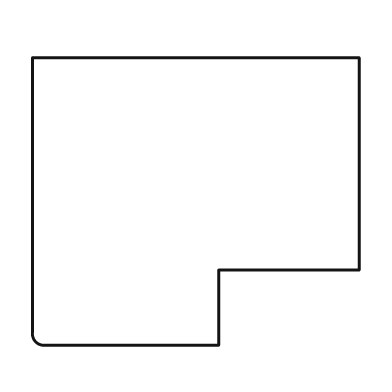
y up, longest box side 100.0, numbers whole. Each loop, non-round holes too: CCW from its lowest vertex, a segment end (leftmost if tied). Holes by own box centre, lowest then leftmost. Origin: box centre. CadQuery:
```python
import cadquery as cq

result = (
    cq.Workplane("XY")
    .moveTo(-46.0, -44.0)
    .lineTo(7.0, -44.0)
    .lineTo(7.0, -21.0)
    .lineTo(50.0, -21.0)
    .lineTo(50.0, 44.0)
    .lineTo(-50.0, 44.0)
    .lineTo(-50.0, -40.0)
    .threePointArc((-49.0, -43.0), (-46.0, -44.0))
    .close()
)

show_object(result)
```